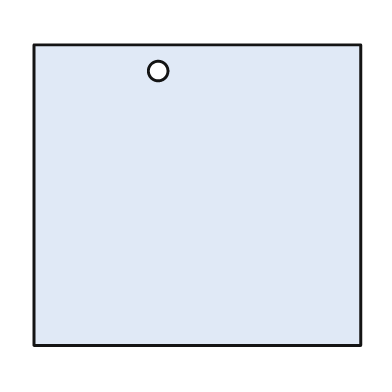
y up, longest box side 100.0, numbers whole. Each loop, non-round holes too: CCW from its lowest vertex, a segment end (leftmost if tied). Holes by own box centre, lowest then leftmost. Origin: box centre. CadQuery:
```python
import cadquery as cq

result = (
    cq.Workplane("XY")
    .moveTo(-50.0, -46.0)
    .lineTo(50.0, -46.0)
    .lineTo(50.0, 46.0)
    .lineTo(-50.0, 46.0)
    .close()
    .moveTo(-12.0, 38.0)
    .circle(3.0)
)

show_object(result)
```